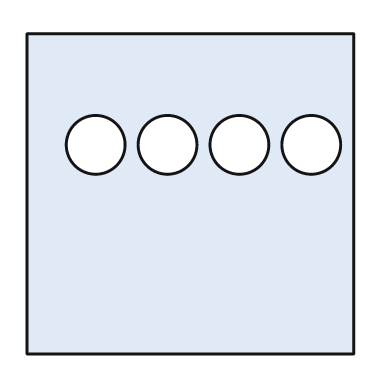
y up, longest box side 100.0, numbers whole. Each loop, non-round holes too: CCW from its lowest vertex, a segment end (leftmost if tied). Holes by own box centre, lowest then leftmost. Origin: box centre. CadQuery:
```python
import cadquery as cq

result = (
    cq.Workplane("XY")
    .moveTo(-50.0, -49.0)
    .lineTo(50.0, -49.0)
    .lineTo(50.0, 49.0)
    .lineTo(-50.0, 49.0)
    .close()
    .moveTo(-29.0, 15.0)
    .circle(9.0)
    .moveTo(-7.0, 15.0)
    .circle(9.0)
    .moveTo(15.0, 15.0)
    .circle(9.0)
    .moveTo(37.0, 15.0)
    .circle(9.0)
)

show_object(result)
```